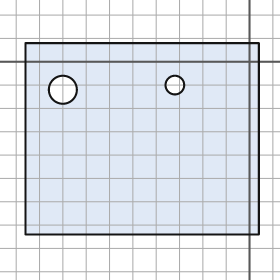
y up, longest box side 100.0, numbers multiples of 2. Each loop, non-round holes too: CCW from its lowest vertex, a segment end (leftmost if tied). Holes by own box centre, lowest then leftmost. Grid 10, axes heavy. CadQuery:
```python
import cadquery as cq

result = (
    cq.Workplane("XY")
    .moveTo(-96.0, -74.0)
    .lineTo(4.0, -74.0)
    .lineTo(4.0, 8.0)
    .lineTo(-96.0, 8.0)
    .close()
    .moveTo(-80.0, -12.0)
    .circle(6.0)
    .moveTo(-32.0, -10.0)
    .circle(4.0)
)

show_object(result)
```